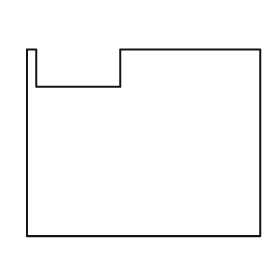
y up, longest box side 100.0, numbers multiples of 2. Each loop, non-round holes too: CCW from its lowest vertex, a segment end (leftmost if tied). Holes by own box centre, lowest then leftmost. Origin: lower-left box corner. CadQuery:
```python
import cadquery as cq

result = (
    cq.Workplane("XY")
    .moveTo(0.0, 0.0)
    .lineTo(100.0, 0.0)
    .lineTo(100.0, 80.0)
    .lineTo(40.0, 80.0)
    .lineTo(40.0, 64.0)
    .lineTo(4.0, 64.0)
    .lineTo(4.0, 80.0)
    .lineTo(0.0, 80.0)
    .close()
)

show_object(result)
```